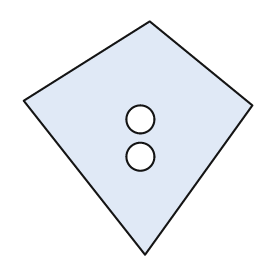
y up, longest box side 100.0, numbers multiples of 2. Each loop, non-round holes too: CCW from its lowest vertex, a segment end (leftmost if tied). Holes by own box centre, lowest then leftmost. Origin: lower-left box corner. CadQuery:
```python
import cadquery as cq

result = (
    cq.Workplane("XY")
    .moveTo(52.0, 0.0)
    .lineTo(98.0, 64.0)
    .lineTo(54.0, 100.0)
    .lineTo(0.0, 66.0)
    .close()
    .moveTo(50.0, 42.0)
    .circle(6.0)
    .moveTo(50.0, 58.0)
    .circle(6.0)
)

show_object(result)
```